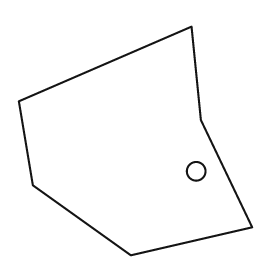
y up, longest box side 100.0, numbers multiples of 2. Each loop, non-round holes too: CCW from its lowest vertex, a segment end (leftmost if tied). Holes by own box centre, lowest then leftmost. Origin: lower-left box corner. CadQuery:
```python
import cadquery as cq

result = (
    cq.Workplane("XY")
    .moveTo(48.0, 0.0)
    .lineTo(100.0, 12.0)
    .lineTo(78.0, 58.0)
    .lineTo(74.0, 98.0)
    .lineTo(0.0, 66.0)
    .lineTo(6.0, 30.0)
    .close()
    .moveTo(76.0, 36.0)
    .circle(4.0)
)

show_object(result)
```